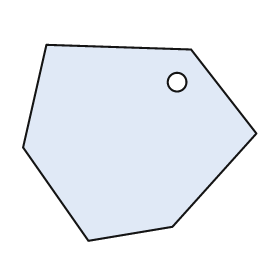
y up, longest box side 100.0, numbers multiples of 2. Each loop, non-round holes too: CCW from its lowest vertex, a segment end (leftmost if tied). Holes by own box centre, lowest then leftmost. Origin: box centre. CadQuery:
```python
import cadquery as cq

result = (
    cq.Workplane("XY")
    .moveTo(-22.0, -42.0)
    .lineTo(14.0, -36.0)
    .lineTo(50.0, 4.0)
    .lineTo(22.0, 40.0)
    .lineTo(-40.0, 42.0)
    .lineTo(-50.0, -2.0)
    .close()
    .moveTo(16.0, 26.0)
    .circle(4.0)
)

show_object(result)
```